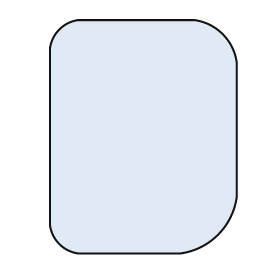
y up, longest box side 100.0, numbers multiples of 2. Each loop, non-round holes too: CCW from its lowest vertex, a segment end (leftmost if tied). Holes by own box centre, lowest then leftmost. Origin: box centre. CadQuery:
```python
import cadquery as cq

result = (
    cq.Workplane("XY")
    .moveTo(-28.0, -50.0)
    .lineTo(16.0, -50.0)
    .threePointArc((32.0, -42.0), (40.0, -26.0))
    .lineTo(40.0, 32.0)
    .threePointArc((34.0, 44.0), (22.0, 50.0))
    .lineTo(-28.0, 50.0)
    .threePointArc((-36.0, 46.0), (-40.0, 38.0))
    .lineTo(-40.0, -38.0)
    .threePointArc((-36.0, -46.0), (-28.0, -50.0))
    .close()
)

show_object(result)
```